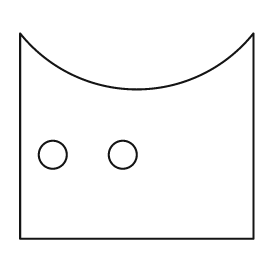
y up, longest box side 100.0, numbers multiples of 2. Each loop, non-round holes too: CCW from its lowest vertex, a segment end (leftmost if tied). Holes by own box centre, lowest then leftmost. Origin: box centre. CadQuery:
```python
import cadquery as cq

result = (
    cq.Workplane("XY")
    .moveTo(-50.0, -44.0)
    .lineTo(50.0, -44.0)
    .lineTo(50.0, 44.0)
    .threePointArc((0.0, 20.0), (-50.0, 44.0))
    .close()
    .moveTo(-36.0, -8.0)
    .circle(6.0)
    .moveTo(-6.0, -8.0)
    .circle(6.0)
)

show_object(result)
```